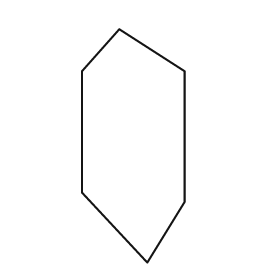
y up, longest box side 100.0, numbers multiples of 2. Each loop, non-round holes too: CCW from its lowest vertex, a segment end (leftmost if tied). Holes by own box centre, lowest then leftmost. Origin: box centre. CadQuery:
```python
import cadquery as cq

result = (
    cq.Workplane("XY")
    .moveTo(6.0, -50.0)
    .lineTo(22.0, -24.0)
    .lineTo(22.0, 32.0)
    .lineTo(-6.0, 50.0)
    .lineTo(-22.0, 32.0)
    .lineTo(-22.0, -20.0)
    .close()
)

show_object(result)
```